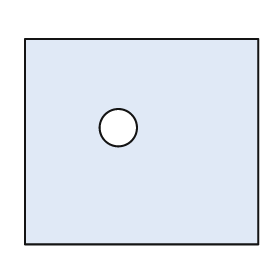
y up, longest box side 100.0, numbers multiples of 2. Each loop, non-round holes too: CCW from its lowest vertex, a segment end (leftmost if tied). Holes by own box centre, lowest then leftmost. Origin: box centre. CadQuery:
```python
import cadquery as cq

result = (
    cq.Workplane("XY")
    .moveTo(-50.0, -44.0)
    .lineTo(50.0, -44.0)
    .lineTo(50.0, 44.0)
    .lineTo(-50.0, 44.0)
    .close()
    .moveTo(-10.0, 6.0)
    .circle(8.0)
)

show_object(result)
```